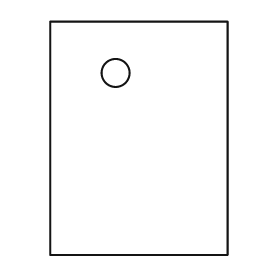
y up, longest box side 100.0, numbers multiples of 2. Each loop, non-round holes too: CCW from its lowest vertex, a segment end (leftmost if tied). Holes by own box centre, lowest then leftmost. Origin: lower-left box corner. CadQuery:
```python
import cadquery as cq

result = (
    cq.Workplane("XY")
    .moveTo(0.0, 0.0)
    .lineTo(76.0, 0.0)
    .lineTo(76.0, 100.0)
    .lineTo(0.0, 100.0)
    .close()
    .moveTo(28.0, 78.0)
    .circle(6.0)
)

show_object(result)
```